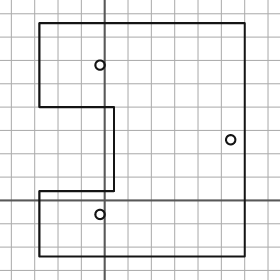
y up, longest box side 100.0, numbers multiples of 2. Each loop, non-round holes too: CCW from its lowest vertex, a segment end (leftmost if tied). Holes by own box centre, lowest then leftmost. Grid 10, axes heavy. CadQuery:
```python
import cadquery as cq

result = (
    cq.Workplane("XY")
    .moveTo(-28.0, -24.0)
    .lineTo(60.0, -24.0)
    .lineTo(60.0, 76.0)
    .lineTo(-28.0, 76.0)
    .lineTo(-28.0, 40.0)
    .lineTo(4.0, 40.0)
    .lineTo(4.0, 4.0)
    .lineTo(-28.0, 4.0)
    .close()
    .moveTo(-2.0, -6.0)
    .circle(2.0)
    .moveTo(54.0, 26.0)
    .circle(2.0)
    .moveTo(-2.0, 58.0)
    .circle(2.0)
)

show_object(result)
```